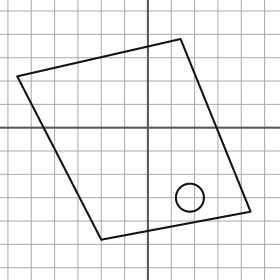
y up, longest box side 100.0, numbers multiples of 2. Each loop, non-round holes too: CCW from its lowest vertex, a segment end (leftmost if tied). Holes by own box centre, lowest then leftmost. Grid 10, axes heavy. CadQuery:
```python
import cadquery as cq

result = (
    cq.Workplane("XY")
    .moveTo(-20.0, -48.0)
    .lineTo(44.0, -36.0)
    .lineTo(14.0, 38.0)
    .lineTo(-56.0, 22.0)
    .close()
    .moveTo(18.0, -30.0)
    .circle(6.0)
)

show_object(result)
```